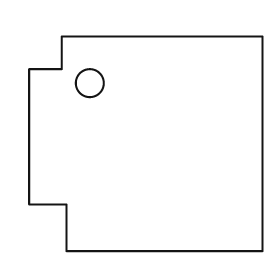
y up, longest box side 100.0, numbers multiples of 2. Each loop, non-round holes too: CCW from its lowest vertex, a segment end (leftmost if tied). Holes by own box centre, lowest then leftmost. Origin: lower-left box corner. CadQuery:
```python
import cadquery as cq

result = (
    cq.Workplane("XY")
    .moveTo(16.0, 0.0)
    .lineTo(100.0, 0.0)
    .lineTo(100.0, 92.0)
    .lineTo(14.0, 92.0)
    .lineTo(14.0, 78.0)
    .lineTo(0.0, 78.0)
    .lineTo(0.0, 20.0)
    .lineTo(16.0, 20.0)
    .close()
    .moveTo(26.0, 72.0)
    .circle(6.0)
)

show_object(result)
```